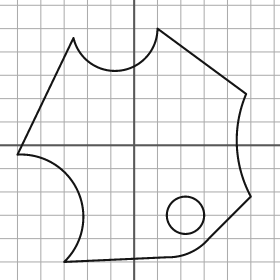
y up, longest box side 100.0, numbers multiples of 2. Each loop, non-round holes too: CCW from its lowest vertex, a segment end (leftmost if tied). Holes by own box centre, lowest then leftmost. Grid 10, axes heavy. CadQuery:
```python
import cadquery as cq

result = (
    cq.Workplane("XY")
    .moveTo(-30.0, -50.0)
    .lineTo(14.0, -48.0)
    .threePointArc((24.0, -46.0), (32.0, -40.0))
    .lineTo(50.0, -22.0)
    .threePointArc((44.0, 0.0), (48.0, 22.0))
    .lineTo(10.0, 50.0)
    .threePointArc((-6.0, 32.0), (-26.0, 46.0))
    .lineTo(-50.0, -4.0)
    .threePointArc((-24.0, -20.0), (-30.0, -50.0))
    .close()
    .moveTo(22.0, -30.0)
    .circle(8.0)
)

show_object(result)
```